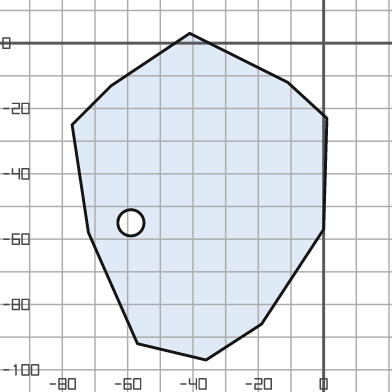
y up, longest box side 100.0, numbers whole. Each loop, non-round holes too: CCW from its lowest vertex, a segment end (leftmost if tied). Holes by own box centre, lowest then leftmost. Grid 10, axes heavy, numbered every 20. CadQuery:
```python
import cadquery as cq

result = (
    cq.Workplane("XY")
    .moveTo(-36.0, -97.0)
    .lineTo(-19.0, -86.0)
    .lineTo(0.0, -57.0)
    .lineTo(1.0, -23.0)
    .lineTo(-11.0, -12.0)
    .lineTo(-41.0, 3.0)
    .lineTo(-65.0, -13.0)
    .lineTo(-77.0, -25.0)
    .lineTo(-72.0, -58.0)
    .lineTo(-57.0, -92.0)
    .close()
    .moveTo(-59.0, -55.0)
    .circle(4.0)
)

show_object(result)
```